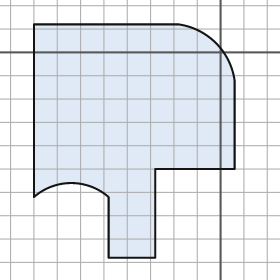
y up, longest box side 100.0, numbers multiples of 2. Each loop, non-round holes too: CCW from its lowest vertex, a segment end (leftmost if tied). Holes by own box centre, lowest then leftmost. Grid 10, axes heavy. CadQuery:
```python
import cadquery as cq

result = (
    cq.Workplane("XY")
    .moveTo(-48.0, -88.0)
    .lineTo(-28.0, -88.0)
    .lineTo(-28.0, -50.0)
    .lineTo(6.0, -50.0)
    .lineTo(6.0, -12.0)
    .threePointArc((-2.0, 4.0), (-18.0, 12.0))
    .lineTo(-80.0, 12.0)
    .lineTo(-80.0, -62.0)
    .threePointArc((-64.0, -56.0), (-48.0, -62.0))
    .close()
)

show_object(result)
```